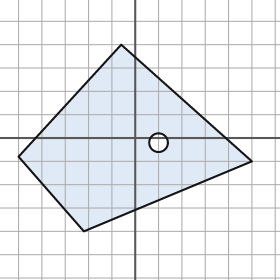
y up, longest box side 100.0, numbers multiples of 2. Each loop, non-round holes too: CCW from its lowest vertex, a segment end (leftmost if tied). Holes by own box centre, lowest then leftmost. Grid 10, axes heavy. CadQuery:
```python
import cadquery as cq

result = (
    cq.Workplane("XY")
    .moveTo(-22.0, -40.0)
    .lineTo(50.0, -10.0)
    .lineTo(-6.0, 40.0)
    .lineTo(-50.0, -8.0)
    .close()
    .moveTo(10.0, -2.0)
    .circle(4.0)
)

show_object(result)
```